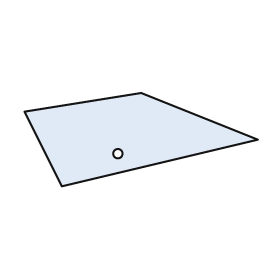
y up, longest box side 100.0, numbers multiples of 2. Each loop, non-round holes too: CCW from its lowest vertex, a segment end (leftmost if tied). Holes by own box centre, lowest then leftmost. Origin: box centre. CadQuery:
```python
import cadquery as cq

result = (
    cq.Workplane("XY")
    .moveTo(-34.0, -20.0)
    .lineTo(50.0, 0.0)
    .lineTo(0.0, 20.0)
    .lineTo(-50.0, 12.0)
    .close()
    .moveTo(-10.0, -6.0)
    .circle(2.0)
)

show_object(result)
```